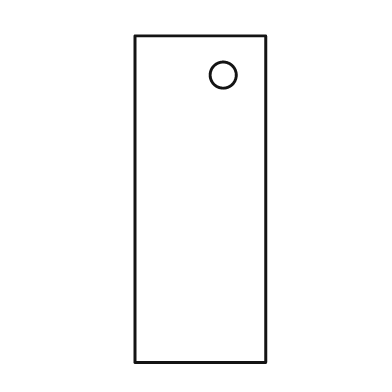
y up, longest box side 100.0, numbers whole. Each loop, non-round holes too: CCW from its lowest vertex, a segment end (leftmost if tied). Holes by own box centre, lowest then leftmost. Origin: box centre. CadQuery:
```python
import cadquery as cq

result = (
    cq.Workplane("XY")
    .moveTo(-20.0, -50.0)
    .lineTo(20.0, -50.0)
    .lineTo(20.0, 50.0)
    .lineTo(-20.0, 50.0)
    .close()
    .moveTo(7.0, 38.0)
    .circle(4.0)
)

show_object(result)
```